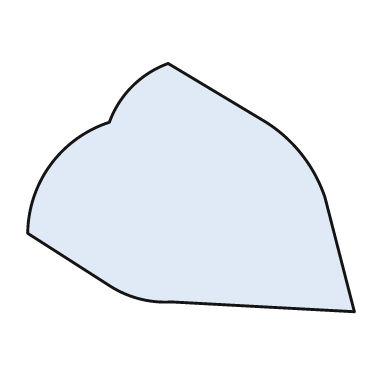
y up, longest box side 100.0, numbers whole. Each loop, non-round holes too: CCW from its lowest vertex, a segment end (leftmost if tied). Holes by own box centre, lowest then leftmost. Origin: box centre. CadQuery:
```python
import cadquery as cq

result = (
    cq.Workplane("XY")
    .moveTo(50.0, -38.0)
    .lineTo(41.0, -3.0)
    .threePointArc((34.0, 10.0), (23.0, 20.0))
    .lineTo(-7.0, 38.0)
    .threePointArc((-18.0, 31.0), (-25.0, 20.0))
    .threePointArc((-43.0, 7.0), (-50.0, -14.0))
    .lineTo(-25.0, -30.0)
    .threePointArc((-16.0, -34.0), (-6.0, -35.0))
    .close()
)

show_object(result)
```